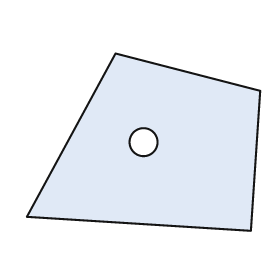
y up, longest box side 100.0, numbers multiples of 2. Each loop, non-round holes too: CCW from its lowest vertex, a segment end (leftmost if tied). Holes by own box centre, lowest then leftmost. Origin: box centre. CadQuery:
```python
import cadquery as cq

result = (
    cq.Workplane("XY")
    .moveTo(46.0, -38.0)
    .lineTo(50.0, 22.0)
    .lineTo(-12.0, 38.0)
    .lineTo(-50.0, -32.0)
    .close()
    .moveTo(0.0, 0.0)
    .circle(6.0)
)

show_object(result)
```